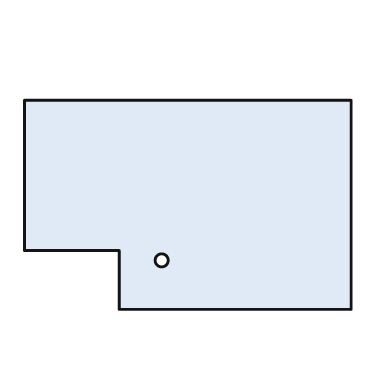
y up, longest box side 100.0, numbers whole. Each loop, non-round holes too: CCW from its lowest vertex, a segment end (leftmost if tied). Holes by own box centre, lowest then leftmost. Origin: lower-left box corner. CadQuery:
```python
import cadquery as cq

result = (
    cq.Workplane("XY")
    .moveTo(29.0, 0.0)
    .lineTo(100.0, 0.0)
    .lineTo(100.0, 64.0)
    .lineTo(0.0, 64.0)
    .lineTo(0.0, 18.0)
    .lineTo(29.0, 18.0)
    .close()
    .moveTo(42.0, 15.0)
    .circle(2.0)
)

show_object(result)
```